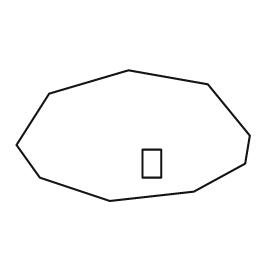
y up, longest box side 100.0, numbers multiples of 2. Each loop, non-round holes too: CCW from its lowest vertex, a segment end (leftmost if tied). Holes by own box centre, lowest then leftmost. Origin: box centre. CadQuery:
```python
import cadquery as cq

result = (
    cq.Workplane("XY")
    .moveTo(-10.0, -28.0)
    .lineTo(26.0, -24.0)
    .lineTo(48.0, -12.0)
    .lineTo(50.0, 0.0)
    .lineTo(32.0, 22.0)
    .lineTo(-2.0, 28.0)
    .lineTo(-36.0, 18.0)
    .lineTo(-50.0, -4.0)
    .lineTo(-40.0, -18.0)
    .close()
    .moveTo(4.0, -18.0)
    .lineTo(12.0, -18.0)
    .lineTo(12.0, -6.0)
    .lineTo(4.0, -6.0)
    .close()
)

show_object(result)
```